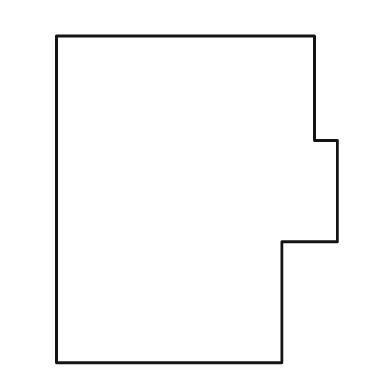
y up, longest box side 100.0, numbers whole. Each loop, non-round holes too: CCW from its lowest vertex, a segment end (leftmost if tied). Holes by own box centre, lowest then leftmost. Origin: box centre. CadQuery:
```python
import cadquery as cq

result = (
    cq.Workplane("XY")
    .moveTo(-43.0, -50.0)
    .lineTo(26.0, -50.0)
    .lineTo(26.0, -13.0)
    .lineTo(43.0, -13.0)
    .lineTo(43.0, 18.0)
    .lineTo(36.0, 18.0)
    .lineTo(36.0, 50.0)
    .lineTo(-43.0, 50.0)
    .close()
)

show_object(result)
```